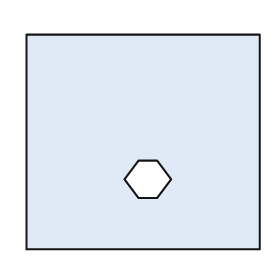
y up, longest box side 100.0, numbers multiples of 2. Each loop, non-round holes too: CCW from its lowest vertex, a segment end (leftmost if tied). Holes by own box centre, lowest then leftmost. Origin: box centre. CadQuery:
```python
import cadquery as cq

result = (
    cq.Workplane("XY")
    .moveTo(-50.0, -46.0)
    .lineTo(50.0, -46.0)
    .lineTo(50.0, 46.0)
    .lineTo(-50.0, 46.0)
    .close()
    .moveTo(-2.0, -24.0)
    .lineTo(6.0, -24.0)
    .lineTo(12.0, -16.0)
    .lineTo(6.0, -8.0)
    .lineTo(-2.0, -8.0)
    .lineTo(-8.0, -16.0)
    .close()
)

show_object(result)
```